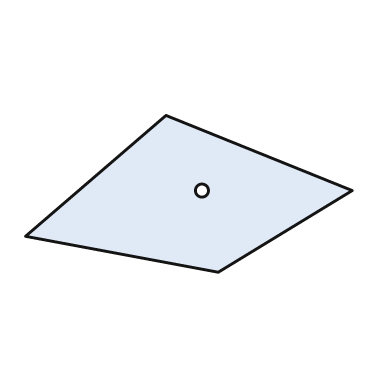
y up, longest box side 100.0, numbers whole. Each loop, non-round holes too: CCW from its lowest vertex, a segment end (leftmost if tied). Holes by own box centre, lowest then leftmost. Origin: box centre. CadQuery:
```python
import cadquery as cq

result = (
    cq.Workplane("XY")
    .moveTo(9.0, -24.0)
    .lineTo(50.0, 1.0)
    .lineTo(-7.0, 24.0)
    .lineTo(-50.0, -13.0)
    .close()
    .moveTo(4.0, 1.0)
    .circle(2.0)
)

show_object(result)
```